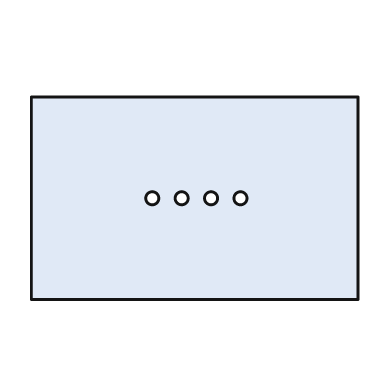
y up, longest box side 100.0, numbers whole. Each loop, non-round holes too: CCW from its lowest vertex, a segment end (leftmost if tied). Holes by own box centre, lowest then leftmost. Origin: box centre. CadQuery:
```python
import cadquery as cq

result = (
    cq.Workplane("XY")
    .moveTo(-50.0, -31.0)
    .lineTo(50.0, -31.0)
    .lineTo(50.0, 31.0)
    .lineTo(-50.0, 31.0)
    .close()
    .moveTo(-13.0, 0.0)
    .circle(2.0)
    .moveTo(-4.0, 0.0)
    .circle(2.0)
    .moveTo(5.0, 0.0)
    .circle(2.0)
    .moveTo(14.0, 0.0)
    .circle(2.0)
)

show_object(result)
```